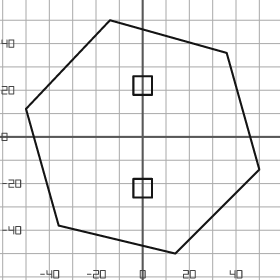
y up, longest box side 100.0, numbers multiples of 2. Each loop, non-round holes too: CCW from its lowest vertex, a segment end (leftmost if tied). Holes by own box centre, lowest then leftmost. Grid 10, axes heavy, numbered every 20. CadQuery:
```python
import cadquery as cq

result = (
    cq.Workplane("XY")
    .moveTo(14.0, -50.0)
    .lineTo(50.0, -14.0)
    .lineTo(36.0, 36.0)
    .lineTo(-14.0, 50.0)
    .lineTo(-50.0, 12.0)
    .lineTo(-36.0, -38.0)
    .close()
    .moveTo(-4.0, -26.0)
    .lineTo(4.0, -26.0)
    .lineTo(4.0, -18.0)
    .lineTo(-4.0, -18.0)
    .close()
    .moveTo(-4.0, 18.0)
    .lineTo(4.0, 18.0)
    .lineTo(4.0, 26.0)
    .lineTo(-4.0, 26.0)
    .close()
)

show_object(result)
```